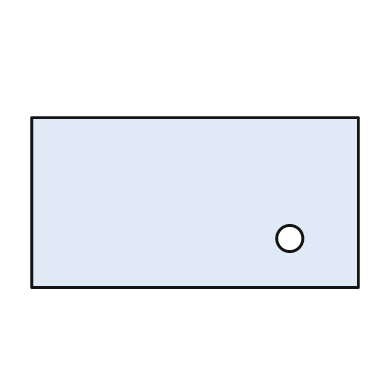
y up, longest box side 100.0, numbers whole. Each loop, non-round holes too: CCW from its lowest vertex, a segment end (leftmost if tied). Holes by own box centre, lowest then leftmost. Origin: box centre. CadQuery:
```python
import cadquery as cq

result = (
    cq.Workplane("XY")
    .moveTo(-50.0, -26.0)
    .lineTo(50.0, -26.0)
    .lineTo(50.0, 26.0)
    .lineTo(-50.0, 26.0)
    .close()
    .moveTo(29.0, -11.0)
    .circle(4.0)
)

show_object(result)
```